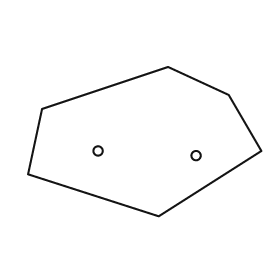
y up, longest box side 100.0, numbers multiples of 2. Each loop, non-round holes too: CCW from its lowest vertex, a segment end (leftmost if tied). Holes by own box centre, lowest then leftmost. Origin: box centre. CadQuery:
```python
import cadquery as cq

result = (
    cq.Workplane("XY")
    .moveTo(6.0, -32.0)
    .lineTo(50.0, -4.0)
    .lineTo(36.0, 20.0)
    .lineTo(10.0, 32.0)
    .lineTo(-44.0, 14.0)
    .lineTo(-50.0, -14.0)
    .close()
    .moveTo(22.0, -6.0)
    .circle(2.0)
    .moveTo(-20.0, -4.0)
    .circle(2.0)
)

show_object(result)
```